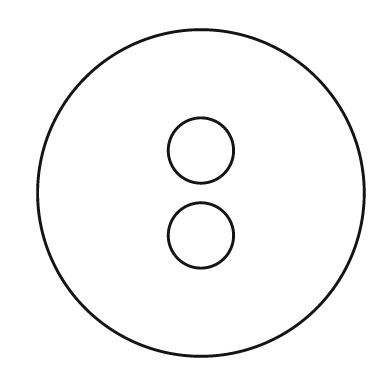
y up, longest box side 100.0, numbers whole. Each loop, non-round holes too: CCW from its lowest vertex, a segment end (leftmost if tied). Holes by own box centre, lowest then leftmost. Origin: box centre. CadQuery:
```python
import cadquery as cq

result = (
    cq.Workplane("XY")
    .moveTo(0.0, 0.0)
    .circle(50.0)
    .moveTo(0.0, -13.0)
    .circle(10.0)
    .moveTo(0.0, 13.0)
    .circle(10.0)
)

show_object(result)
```